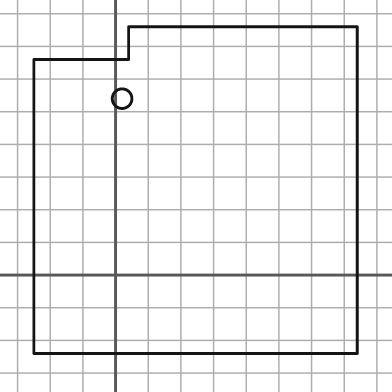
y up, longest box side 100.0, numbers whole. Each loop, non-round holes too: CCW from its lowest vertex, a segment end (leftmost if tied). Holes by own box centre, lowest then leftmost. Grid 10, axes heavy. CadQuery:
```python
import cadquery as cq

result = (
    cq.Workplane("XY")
    .moveTo(-25.0, -24.0)
    .lineTo(74.0, -24.0)
    .lineTo(74.0, 76.0)
    .lineTo(4.0, 76.0)
    .lineTo(4.0, 66.0)
    .lineTo(-25.0, 66.0)
    .close()
    .moveTo(2.0, 54.0)
    .circle(3.0)
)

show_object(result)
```